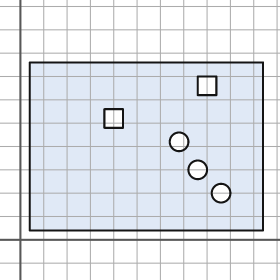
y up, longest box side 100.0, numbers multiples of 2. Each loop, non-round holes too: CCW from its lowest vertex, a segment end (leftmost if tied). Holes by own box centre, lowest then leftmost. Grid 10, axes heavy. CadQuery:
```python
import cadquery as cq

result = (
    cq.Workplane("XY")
    .moveTo(4.0, 4.0)
    .lineTo(104.0, 4.0)
    .lineTo(104.0, 76.0)
    .lineTo(4.0, 76.0)
    .close()
    .moveTo(86.0, 20.0)
    .circle(4.0)
    .moveTo(76.0, 30.0)
    .circle(4.0)
    .moveTo(68.0, 42.0)
    .circle(4.0)
    .moveTo(36.0, 48.0)
    .lineTo(44.0, 48.0)
    .lineTo(44.0, 56.0)
    .lineTo(36.0, 56.0)
    .close()
    .moveTo(76.0, 62.0)
    .lineTo(84.0, 62.0)
    .lineTo(84.0, 70.0)
    .lineTo(76.0, 70.0)
    .close()
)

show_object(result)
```